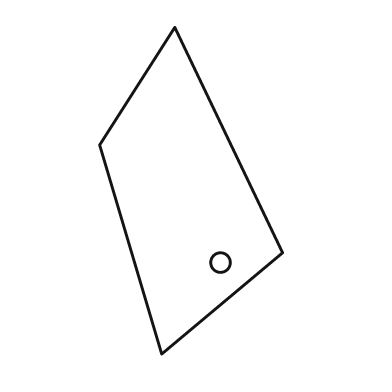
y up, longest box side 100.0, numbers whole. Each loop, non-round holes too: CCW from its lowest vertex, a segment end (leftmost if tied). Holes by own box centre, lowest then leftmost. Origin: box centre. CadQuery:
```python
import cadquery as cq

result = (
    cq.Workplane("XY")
    .moveTo(-9.0, -50.0)
    .lineTo(28.0, -19.0)
    .lineTo(-5.0, 50.0)
    .lineTo(-28.0, 14.0)
    .close()
    .moveTo(9.0, -22.0)
    .circle(3.0)
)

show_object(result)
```